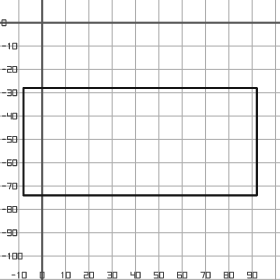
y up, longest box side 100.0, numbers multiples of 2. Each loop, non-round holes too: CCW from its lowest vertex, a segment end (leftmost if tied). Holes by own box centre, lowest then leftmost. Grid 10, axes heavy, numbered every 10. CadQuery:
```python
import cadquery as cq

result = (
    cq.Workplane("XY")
    .moveTo(-8.0, -74.0)
    .lineTo(92.0, -74.0)
    .lineTo(92.0, -28.0)
    .lineTo(-8.0, -28.0)
    .close()
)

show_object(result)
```